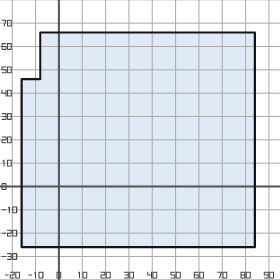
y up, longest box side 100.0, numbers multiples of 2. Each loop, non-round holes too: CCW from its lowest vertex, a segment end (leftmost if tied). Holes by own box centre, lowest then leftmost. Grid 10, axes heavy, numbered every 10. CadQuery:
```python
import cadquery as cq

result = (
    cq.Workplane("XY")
    .moveTo(-16.0, -26.0)
    .lineTo(84.0, -26.0)
    .lineTo(84.0, 66.0)
    .lineTo(-8.0, 66.0)
    .lineTo(-8.0, 46.0)
    .lineTo(-16.0, 46.0)
    .close()
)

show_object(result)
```